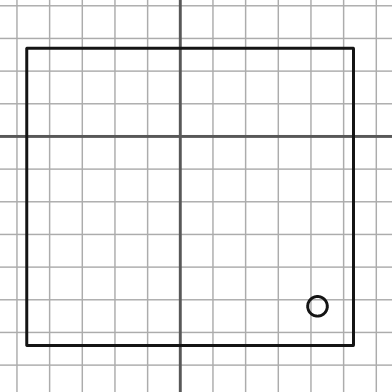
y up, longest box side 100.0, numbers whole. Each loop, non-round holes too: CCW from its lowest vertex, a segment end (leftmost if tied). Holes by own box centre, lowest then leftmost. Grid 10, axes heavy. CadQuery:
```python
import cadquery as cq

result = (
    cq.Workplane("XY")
    .moveTo(-47.0, -64.0)
    .lineTo(53.0, -64.0)
    .lineTo(53.0, 27.0)
    .lineTo(-47.0, 27.0)
    .close()
    .moveTo(42.0, -52.0)
    .circle(3.0)
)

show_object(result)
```